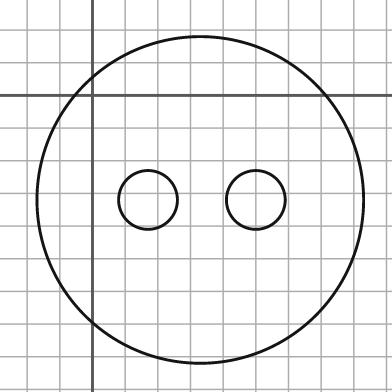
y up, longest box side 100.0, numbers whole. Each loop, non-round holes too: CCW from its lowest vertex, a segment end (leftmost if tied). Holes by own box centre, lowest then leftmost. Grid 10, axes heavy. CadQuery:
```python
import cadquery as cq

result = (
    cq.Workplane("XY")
    .moveTo(33.0, -32.0)
    .circle(50.0)
    .moveTo(17.0, -32.0)
    .circle(9.0)
    .moveTo(50.0, -32.0)
    .circle(9.0)
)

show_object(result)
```